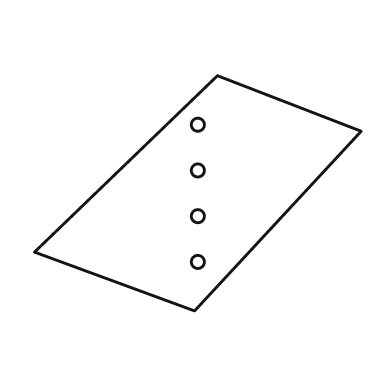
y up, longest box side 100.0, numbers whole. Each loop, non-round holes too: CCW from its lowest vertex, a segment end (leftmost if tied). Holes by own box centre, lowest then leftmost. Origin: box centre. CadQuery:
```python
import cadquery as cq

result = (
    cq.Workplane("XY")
    .moveTo(-1.0, -36.0)
    .lineTo(50.0, 19.0)
    .lineTo(6.0, 36.0)
    .lineTo(-50.0, -18.0)
    .close()
    .moveTo(0.0, -21.0)
    .circle(2.0)
    .moveTo(0.0, -7.0)
    .circle(2.0)
    .moveTo(0.0, 7.0)
    .circle(2.0)
    .moveTo(0.0, 21.0)
    .circle(2.0)
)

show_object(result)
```